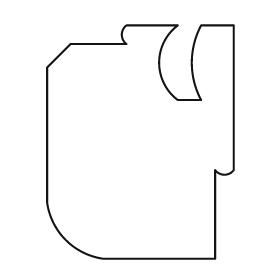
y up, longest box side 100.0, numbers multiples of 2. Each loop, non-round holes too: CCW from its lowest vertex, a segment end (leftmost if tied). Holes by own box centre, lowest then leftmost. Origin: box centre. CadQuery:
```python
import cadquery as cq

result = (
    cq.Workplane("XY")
    .moveTo(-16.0, -50.0)
    .lineTo(32.0, -50.0)
    .lineTo(32.0, -12.0)
    .threePointArc((36.0, -14.0), (40.0, -12.0))
    .lineTo(40.0, 50.0)
    .lineTo(26.0, 50.0)
    .threePointArc((22.0, 34.0), (26.0, 18.0))
    .lineTo(16.0, 18.0)
    .threePointArc((8.0, 34.0), (16.0, 50.0))
    .lineTo(-6.0, 50.0)
    .threePointArc((-8.0, 46.0), (-6.0, 42.0))
    .lineTo(-30.0, 42.0)
    .lineTo(-40.0, 32.0)
    .lineTo(-40.0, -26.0)
    .threePointArc((-32.0, -42.0), (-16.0, -50.0))
    .close()
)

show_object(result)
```